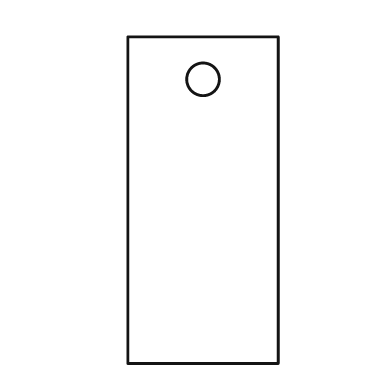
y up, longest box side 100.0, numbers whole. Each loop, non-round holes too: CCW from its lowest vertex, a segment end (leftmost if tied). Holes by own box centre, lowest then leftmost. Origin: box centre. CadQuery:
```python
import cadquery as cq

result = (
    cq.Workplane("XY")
    .moveTo(-23.0, -50.0)
    .lineTo(23.0, -50.0)
    .lineTo(23.0, 50.0)
    .lineTo(-23.0, 50.0)
    .close()
    .moveTo(0.0, 37.0)
    .circle(5.0)
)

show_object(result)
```